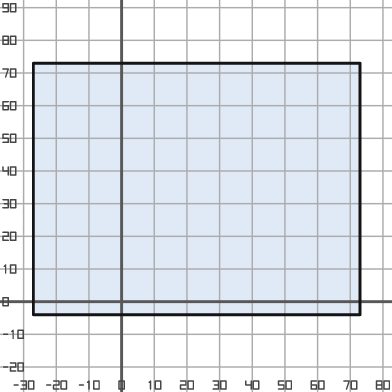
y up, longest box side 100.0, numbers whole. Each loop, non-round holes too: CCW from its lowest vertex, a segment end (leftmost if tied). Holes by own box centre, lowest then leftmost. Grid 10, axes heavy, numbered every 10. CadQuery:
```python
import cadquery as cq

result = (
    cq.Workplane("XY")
    .moveTo(-27.0, -4.0)
    .lineTo(73.0, -4.0)
    .lineTo(73.0, 73.0)
    .lineTo(-27.0, 73.0)
    .close()
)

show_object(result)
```